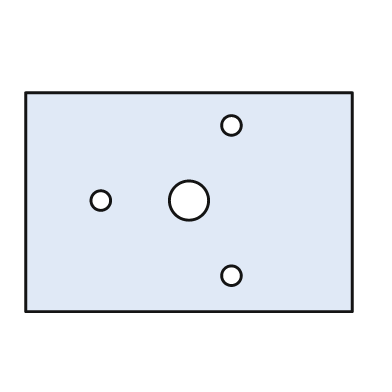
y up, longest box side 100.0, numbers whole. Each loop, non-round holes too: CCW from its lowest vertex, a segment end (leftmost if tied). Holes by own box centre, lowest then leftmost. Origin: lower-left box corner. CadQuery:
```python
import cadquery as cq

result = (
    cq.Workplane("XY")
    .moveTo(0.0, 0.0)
    .lineTo(100.0, 0.0)
    .lineTo(100.0, 67.0)
    .lineTo(0.0, 67.0)
    .close()
    .moveTo(63.0, 11.0)
    .circle(3.0)
    .moveTo(23.0, 34.0)
    .circle(3.0)
    .moveTo(50.0, 34.0)
    .circle(6.0)
    .moveTo(63.0, 57.0)
    .circle(3.0)
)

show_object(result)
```